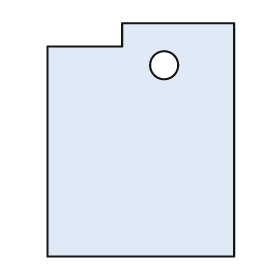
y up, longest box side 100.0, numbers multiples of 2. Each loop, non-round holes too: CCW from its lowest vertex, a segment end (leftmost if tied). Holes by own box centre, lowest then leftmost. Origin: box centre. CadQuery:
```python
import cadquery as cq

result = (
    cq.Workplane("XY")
    .moveTo(-40.0, -50.0)
    .lineTo(40.0, -50.0)
    .lineTo(40.0, 50.0)
    .lineTo(-8.0, 50.0)
    .lineTo(-8.0, 40.0)
    .lineTo(-40.0, 40.0)
    .close()
    .moveTo(10.0, 32.0)
    .circle(6.0)
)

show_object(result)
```